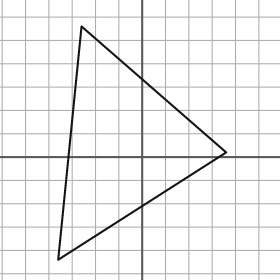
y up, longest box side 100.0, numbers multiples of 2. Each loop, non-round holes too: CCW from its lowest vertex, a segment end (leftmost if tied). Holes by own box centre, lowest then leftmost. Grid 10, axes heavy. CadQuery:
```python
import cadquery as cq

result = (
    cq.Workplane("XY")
    .moveTo(-36.0, -44.0)
    .lineTo(36.0, 2.0)
    .lineTo(-26.0, 56.0)
    .close()
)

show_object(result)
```